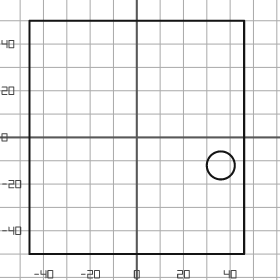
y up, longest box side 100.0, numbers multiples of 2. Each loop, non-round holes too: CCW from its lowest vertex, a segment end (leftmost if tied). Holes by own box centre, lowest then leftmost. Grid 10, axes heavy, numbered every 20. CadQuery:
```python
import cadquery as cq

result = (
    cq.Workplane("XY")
    .moveTo(-46.0, -50.0)
    .lineTo(46.0, -50.0)
    .lineTo(46.0, 50.0)
    .lineTo(-46.0, 50.0)
    .close()
    .moveTo(36.0, -12.0)
    .circle(6.0)
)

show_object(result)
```